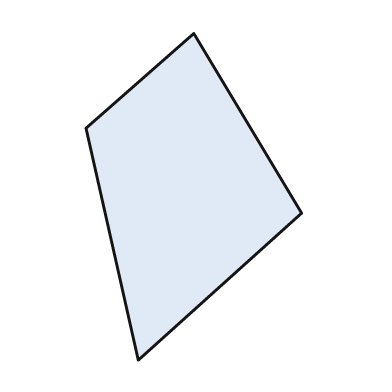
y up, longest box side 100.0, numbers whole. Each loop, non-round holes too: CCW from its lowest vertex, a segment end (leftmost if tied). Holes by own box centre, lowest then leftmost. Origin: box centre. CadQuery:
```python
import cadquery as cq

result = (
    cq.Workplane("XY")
    .moveTo(-17.0, -50.0)
    .lineTo(33.0, -5.0)
    .lineTo(0.0, 50.0)
    .lineTo(-33.0, 21.0)
    .close()
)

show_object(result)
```